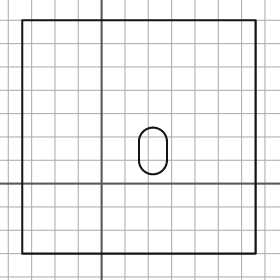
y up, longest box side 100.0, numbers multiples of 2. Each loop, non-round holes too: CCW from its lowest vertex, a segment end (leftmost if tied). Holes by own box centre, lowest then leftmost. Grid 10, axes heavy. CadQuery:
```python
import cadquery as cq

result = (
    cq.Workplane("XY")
    .moveTo(-34.0, -30.0)
    .lineTo(66.0, -30.0)
    .lineTo(66.0, 70.0)
    .lineTo(-34.0, 70.0)
    .close()
    .moveTo(16.0, 10.0)
    .threePointArc((22.0, 4.0), (28.0, 10.0))
    .lineTo(28.0, 18.0)
    .threePointArc((22.0, 24.0), (16.0, 18.0))
    .close()
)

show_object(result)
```